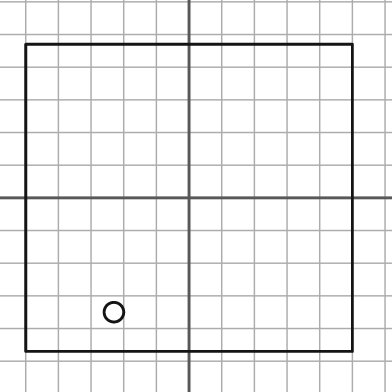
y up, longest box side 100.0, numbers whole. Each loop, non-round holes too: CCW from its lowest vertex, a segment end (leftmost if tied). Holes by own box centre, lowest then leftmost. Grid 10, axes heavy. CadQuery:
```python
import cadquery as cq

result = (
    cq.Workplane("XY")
    .moveTo(-50.0, -47.0)
    .lineTo(50.0, -47.0)
    .lineTo(50.0, 47.0)
    .lineTo(-50.0, 47.0)
    .close()
    .moveTo(-23.0, -35.0)
    .circle(3.0)
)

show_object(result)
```